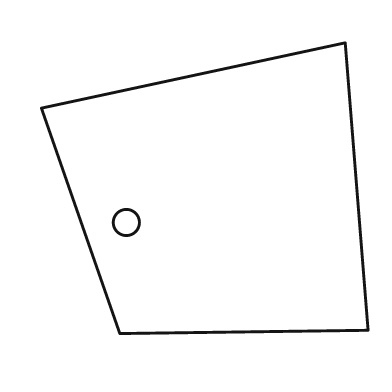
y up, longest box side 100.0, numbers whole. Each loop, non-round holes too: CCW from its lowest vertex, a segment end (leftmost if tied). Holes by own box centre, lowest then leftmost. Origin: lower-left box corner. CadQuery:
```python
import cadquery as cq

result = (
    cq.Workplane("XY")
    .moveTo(24.0, 0.0)
    .lineTo(100.0, 1.0)
    .lineTo(93.0, 89.0)
    .lineTo(0.0, 69.0)
    .close()
    .moveTo(26.0, 34.0)
    .circle(4.0)
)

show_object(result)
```